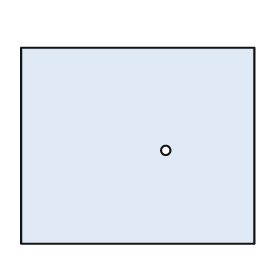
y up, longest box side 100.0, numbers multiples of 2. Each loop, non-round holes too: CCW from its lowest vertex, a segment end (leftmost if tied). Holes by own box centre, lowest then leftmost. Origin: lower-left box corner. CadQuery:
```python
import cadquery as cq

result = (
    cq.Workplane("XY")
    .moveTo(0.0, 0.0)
    .lineTo(100.0, 0.0)
    .lineTo(100.0, 84.0)
    .lineTo(0.0, 84.0)
    .close()
    .moveTo(62.0, 40.0)
    .circle(2.0)
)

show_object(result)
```